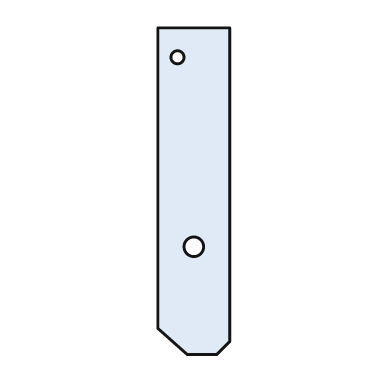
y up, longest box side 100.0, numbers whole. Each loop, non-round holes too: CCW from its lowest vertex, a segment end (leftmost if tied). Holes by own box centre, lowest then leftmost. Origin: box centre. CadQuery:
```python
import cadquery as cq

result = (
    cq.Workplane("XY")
    .moveTo(-2.0, -50.0)
    .lineTo(7.0, -50.0)
    .lineTo(11.0, -46.0)
    .lineTo(11.0, 50.0)
    .lineTo(-11.0, 50.0)
    .lineTo(-11.0, -42.0)
    .close()
    .moveTo(0.0, -17.0)
    .circle(3.0)
    .moveTo(-5.0, 41.0)
    .circle(2.0)
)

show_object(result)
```